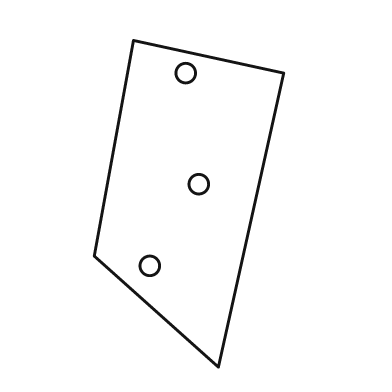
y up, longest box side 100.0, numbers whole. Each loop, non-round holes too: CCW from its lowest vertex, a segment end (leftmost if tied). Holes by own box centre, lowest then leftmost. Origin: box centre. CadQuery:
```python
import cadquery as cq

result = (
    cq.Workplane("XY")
    .moveTo(9.0, -50.0)
    .lineTo(29.0, 40.0)
    .lineTo(-17.0, 50.0)
    .lineTo(-29.0, -16.0)
    .close()
    .moveTo(-12.0, -19.0)
    .circle(3.0)
    .moveTo(3.0, 6.0)
    .circle(3.0)
    .moveTo(-1.0, 40.0)
    .circle(3.0)
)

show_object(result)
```